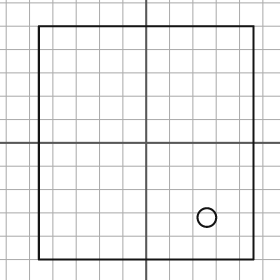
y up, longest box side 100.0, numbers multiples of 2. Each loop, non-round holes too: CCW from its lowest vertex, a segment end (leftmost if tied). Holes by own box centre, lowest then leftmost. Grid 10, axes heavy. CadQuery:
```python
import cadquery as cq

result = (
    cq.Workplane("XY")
    .moveTo(-46.0, -50.0)
    .lineTo(46.0, -50.0)
    .lineTo(46.0, 50.0)
    .lineTo(-46.0, 50.0)
    .close()
    .moveTo(26.0, -32.0)
    .circle(4.0)
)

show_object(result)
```